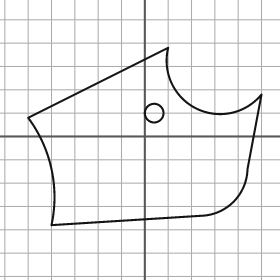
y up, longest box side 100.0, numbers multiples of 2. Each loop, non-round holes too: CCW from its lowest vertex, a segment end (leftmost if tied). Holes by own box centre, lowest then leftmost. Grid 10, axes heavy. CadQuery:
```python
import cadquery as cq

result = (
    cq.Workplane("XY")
    .moveTo(-40.0, -38.0)
    .lineTo(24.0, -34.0)
    .threePointArc((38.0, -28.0), (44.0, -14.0))
    .lineTo(50.0, 18.0)
    .threePointArc((22.0, 12.0), (10.0, 38.0))
    .lineTo(-50.0, 8.0)
    .threePointArc((-40.0, -14.0), (-40.0, -38.0))
    .close()
    .moveTo(4.0, 10.0)
    .circle(4.0)
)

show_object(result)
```